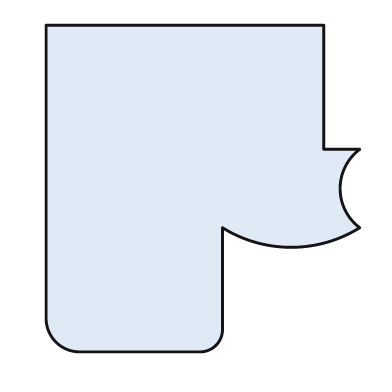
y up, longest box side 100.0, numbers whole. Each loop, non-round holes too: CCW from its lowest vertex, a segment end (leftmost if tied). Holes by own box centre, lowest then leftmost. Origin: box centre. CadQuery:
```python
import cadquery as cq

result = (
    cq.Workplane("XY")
    .moveTo(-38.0, -50.0)
    .lineTo(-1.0, -50.0)
    .threePointArc((4.0, -48.0), (6.0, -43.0))
    .lineTo(6.0, -12.0)
    .threePointArc((27.0, -18.0), (48.0, -12.0))
    .threePointArc((42.0, 0.0), (48.0, 12.0))
    .lineTo(37.0, 12.0)
    .lineTo(37.0, 50.0)
    .lineTo(-48.0, 50.0)
    .lineTo(-48.0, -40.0)
    .threePointArc((-45.0, -47.0), (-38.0, -50.0))
    .close()
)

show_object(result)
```